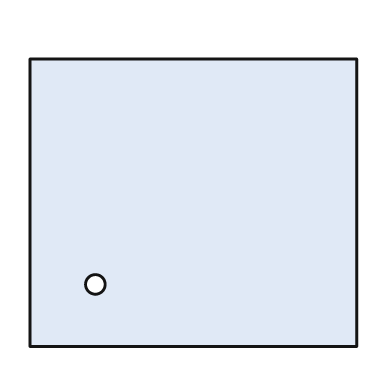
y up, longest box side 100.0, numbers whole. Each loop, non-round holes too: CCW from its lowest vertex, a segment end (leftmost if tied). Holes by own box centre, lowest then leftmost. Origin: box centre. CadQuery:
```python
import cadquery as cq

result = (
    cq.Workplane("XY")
    .moveTo(-50.0, -44.0)
    .lineTo(50.0, -44.0)
    .lineTo(50.0, 44.0)
    .lineTo(-50.0, 44.0)
    .close()
    .moveTo(-30.0, -25.0)
    .circle(3.0)
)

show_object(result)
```